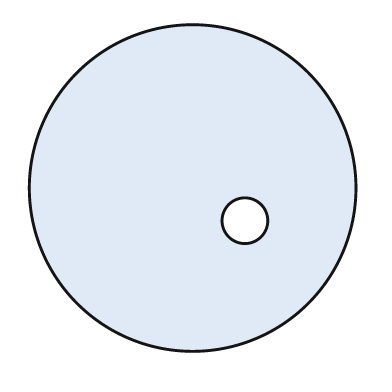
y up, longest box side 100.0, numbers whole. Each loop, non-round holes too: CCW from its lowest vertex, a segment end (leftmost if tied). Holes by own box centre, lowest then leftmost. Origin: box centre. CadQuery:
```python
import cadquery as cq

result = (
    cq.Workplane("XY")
    .moveTo(0.0, 0.0)
    .circle(50.0)
    .moveTo(16.0, -10.0)
    .circle(7.0)
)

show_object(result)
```